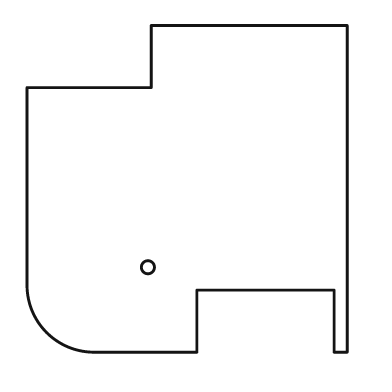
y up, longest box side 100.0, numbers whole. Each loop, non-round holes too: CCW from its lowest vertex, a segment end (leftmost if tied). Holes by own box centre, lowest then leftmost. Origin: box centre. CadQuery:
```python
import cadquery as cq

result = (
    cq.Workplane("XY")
    .moveTo(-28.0, -50.0)
    .lineTo(3.0, -50.0)
    .lineTo(3.0, -31.0)
    .lineTo(45.0, -31.0)
    .lineTo(45.0, -50.0)
    .lineTo(49.0, -50.0)
    .lineTo(49.0, 50.0)
    .lineTo(-11.0, 50.0)
    .lineTo(-11.0, 31.0)
    .lineTo(-49.0, 31.0)
    .lineTo(-49.0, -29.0)
    .threePointArc((-43.0, -44.0), (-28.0, -50.0))
    .close()
    .moveTo(-12.0, -24.0)
    .circle(2.0)
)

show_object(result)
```